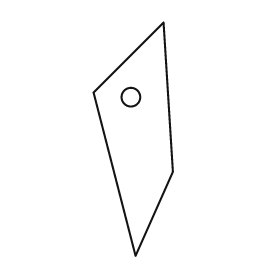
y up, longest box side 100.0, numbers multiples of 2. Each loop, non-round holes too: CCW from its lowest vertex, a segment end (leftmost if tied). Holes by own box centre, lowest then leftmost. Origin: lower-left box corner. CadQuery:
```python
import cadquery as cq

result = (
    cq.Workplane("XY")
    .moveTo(18.0, 0.0)
    .lineTo(34.0, 36.0)
    .lineTo(30.0, 100.0)
    .lineTo(0.0, 70.0)
    .close()
    .moveTo(16.0, 68.0)
    .circle(4.0)
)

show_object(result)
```